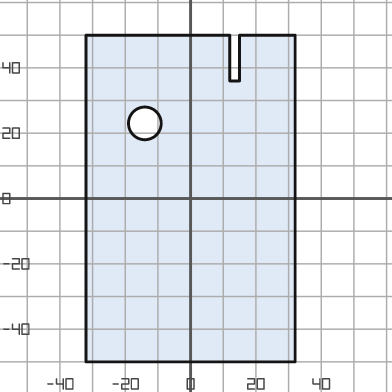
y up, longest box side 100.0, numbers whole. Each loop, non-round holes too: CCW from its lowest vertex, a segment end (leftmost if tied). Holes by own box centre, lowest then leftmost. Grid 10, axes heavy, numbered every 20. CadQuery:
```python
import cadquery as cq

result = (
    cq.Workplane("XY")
    .moveTo(-32.0, -50.0)
    .lineTo(32.0, -50.0)
    .lineTo(32.0, 50.0)
    .lineTo(15.0, 50.0)
    .lineTo(15.0, 36.0)
    .lineTo(12.0, 36.0)
    .lineTo(12.0, 50.0)
    .lineTo(-32.0, 50.0)
    .close()
    .moveTo(-14.0, 23.0)
    .circle(5.0)
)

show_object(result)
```